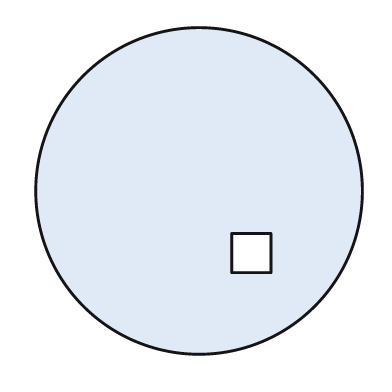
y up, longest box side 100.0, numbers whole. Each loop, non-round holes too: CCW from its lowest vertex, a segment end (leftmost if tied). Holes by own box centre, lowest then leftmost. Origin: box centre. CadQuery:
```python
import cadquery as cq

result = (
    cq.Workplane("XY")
    .moveTo(0.0, 0.0)
    .circle(50.0)
    .moveTo(10.0, -25.0)
    .lineTo(22.0, -25.0)
    .lineTo(22.0, -13.0)
    .lineTo(10.0, -13.0)
    .close()
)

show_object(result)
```